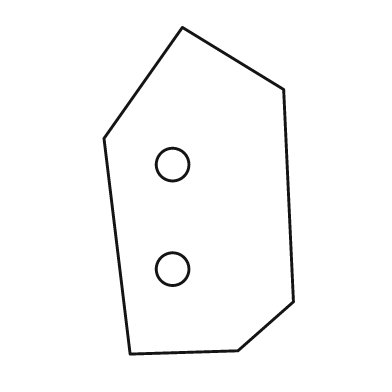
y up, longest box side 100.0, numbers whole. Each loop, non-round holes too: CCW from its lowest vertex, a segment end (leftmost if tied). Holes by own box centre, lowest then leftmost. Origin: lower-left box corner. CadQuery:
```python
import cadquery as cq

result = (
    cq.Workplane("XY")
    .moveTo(8.0, 0.0)
    .lineTo(41.0, 1.0)
    .lineTo(58.0, 16.0)
    .lineTo(55.0, 81.0)
    .lineTo(24.0, 100.0)
    .lineTo(0.0, 66.0)
    .close()
    .moveTo(21.0, 26.0)
    .circle(5.0)
    .moveTo(21.0, 58.0)
    .circle(5.0)
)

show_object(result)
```